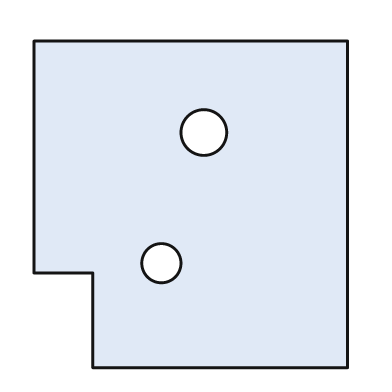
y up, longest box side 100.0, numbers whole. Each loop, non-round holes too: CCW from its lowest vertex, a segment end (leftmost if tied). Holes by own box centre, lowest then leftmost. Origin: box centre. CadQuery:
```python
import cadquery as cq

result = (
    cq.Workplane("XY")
    .moveTo(-30.0, -50.0)
    .lineTo(48.0, -50.0)
    .lineTo(48.0, 50.0)
    .lineTo(-48.0, 50.0)
    .lineTo(-48.0, -21.0)
    .lineTo(-30.0, -21.0)
    .close()
    .moveTo(-9.0, -18.0)
    .circle(6.0)
    .moveTo(4.0, 22.0)
    .circle(7.0)
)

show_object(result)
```